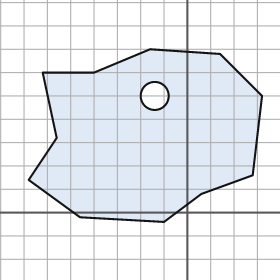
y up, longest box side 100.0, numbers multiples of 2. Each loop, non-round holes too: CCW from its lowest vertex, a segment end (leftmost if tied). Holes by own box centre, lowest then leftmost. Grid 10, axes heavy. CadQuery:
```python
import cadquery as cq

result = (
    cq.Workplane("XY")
    .moveTo(-10.0, -4.0)
    .lineTo(6.0, 8.0)
    .lineTo(28.0, 16.0)
    .lineTo(32.0, 50.0)
    .lineTo(14.0, 68.0)
    .lineTo(-16.0, 70.0)
    .lineTo(-40.0, 60.0)
    .lineTo(-62.0, 60.0)
    .lineTo(-56.0, 32.0)
    .lineTo(-68.0, 14.0)
    .lineTo(-46.0, -2.0)
    .close()
    .moveTo(-14.0, 50.0)
    .circle(6.0)
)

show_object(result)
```